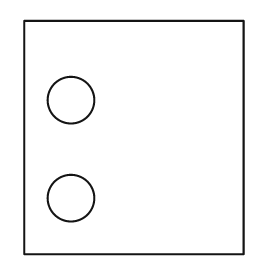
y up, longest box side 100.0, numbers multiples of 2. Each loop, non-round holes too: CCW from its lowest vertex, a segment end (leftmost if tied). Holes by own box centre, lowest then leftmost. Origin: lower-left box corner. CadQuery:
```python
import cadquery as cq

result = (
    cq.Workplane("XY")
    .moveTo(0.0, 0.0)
    .lineTo(94.0, 0.0)
    .lineTo(94.0, 100.0)
    .lineTo(0.0, 100.0)
    .close()
    .moveTo(20.0, 24.0)
    .circle(10.0)
    .moveTo(20.0, 66.0)
    .circle(10.0)
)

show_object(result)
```